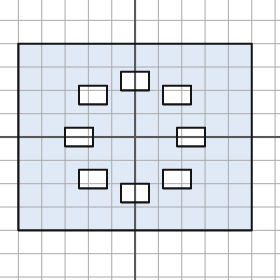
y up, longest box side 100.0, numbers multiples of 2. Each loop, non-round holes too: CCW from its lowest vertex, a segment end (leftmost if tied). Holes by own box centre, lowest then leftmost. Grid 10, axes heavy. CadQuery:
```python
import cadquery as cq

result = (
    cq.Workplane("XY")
    .moveTo(-50.0, -40.0)
    .lineTo(50.0, -40.0)
    .lineTo(50.0, 40.0)
    .lineTo(-50.0, 40.0)
    .close()
    .moveTo(-6.0, -28.0)
    .lineTo(6.0, -28.0)
    .lineTo(6.0, -20.0)
    .lineTo(-6.0, -20.0)
    .close()
    .moveTo(-24.0, -22.0)
    .lineTo(-12.0, -22.0)
    .lineTo(-12.0, -14.0)
    .lineTo(-24.0, -14.0)
    .close()
    .moveTo(12.0, -22.0)
    .lineTo(24.0, -22.0)
    .lineTo(24.0, -14.0)
    .lineTo(12.0, -14.0)
    .close()
    .moveTo(-30.0, -4.0)
    .lineTo(-18.0, -4.0)
    .lineTo(-18.0, 4.0)
    .lineTo(-30.0, 4.0)
    .close()
    .moveTo(18.0, -4.0)
    .lineTo(30.0, -4.0)
    .lineTo(30.0, 4.0)
    .lineTo(18.0, 4.0)
    .close()
    .moveTo(-24.0, 14.0)
    .lineTo(-12.0, 14.0)
    .lineTo(-12.0, 22.0)
    .lineTo(-24.0, 22.0)
    .close()
    .moveTo(12.0, 14.0)
    .lineTo(24.0, 14.0)
    .lineTo(24.0, 22.0)
    .lineTo(12.0, 22.0)
    .close()
    .moveTo(-6.0, 20.0)
    .lineTo(6.0, 20.0)
    .lineTo(6.0, 28.0)
    .lineTo(-6.0, 28.0)
    .close()
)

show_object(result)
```